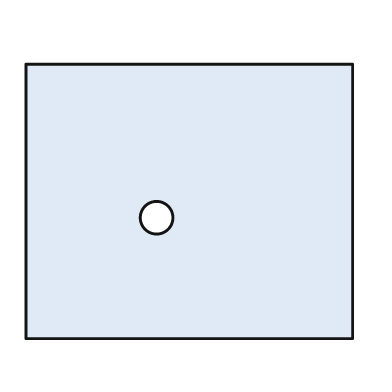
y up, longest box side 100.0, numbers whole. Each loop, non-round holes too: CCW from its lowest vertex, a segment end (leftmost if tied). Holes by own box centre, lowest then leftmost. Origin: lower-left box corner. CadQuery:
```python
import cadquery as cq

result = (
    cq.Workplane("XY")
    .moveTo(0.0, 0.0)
    .lineTo(100.0, 0.0)
    .lineTo(100.0, 84.0)
    .lineTo(0.0, 84.0)
    .close()
    .moveTo(40.0, 37.0)
    .circle(5.0)
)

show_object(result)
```